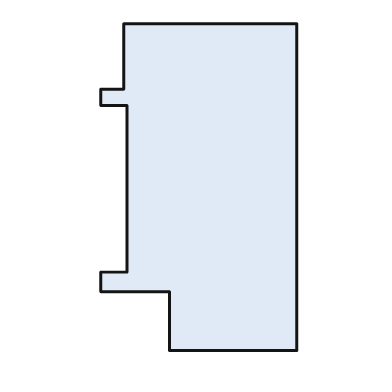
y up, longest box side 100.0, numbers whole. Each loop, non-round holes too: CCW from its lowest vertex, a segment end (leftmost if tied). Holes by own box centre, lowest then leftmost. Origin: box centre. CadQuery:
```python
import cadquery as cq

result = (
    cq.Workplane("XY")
    .moveTo(-9.0, -50.0)
    .lineTo(30.0, -50.0)
    .lineTo(30.0, 50.0)
    .lineTo(-23.0, 50.0)
    .lineTo(-23.0, 30.0)
    .lineTo(-30.0, 30.0)
    .lineTo(-30.0, 25.0)
    .lineTo(-22.0, 25.0)
    .lineTo(-22.0, -26.0)
    .lineTo(-30.0, -26.0)
    .lineTo(-30.0, -32.0)
    .lineTo(-9.0, -32.0)
    .close()
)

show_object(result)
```